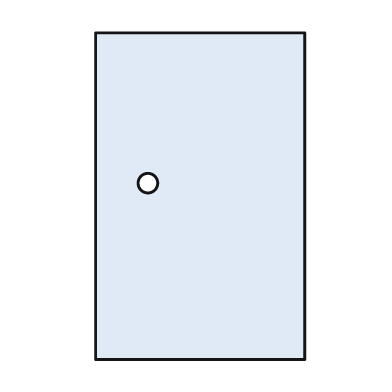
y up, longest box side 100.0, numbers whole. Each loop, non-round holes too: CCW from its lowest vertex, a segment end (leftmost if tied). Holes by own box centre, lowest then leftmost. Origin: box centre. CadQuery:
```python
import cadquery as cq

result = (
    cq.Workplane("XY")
    .moveTo(-32.0, -50.0)
    .lineTo(32.0, -50.0)
    .lineTo(32.0, 50.0)
    .lineTo(-32.0, 50.0)
    .close()
    .moveTo(-16.0, 4.0)
    .circle(3.0)
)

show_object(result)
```